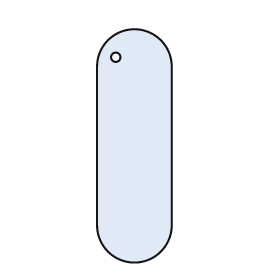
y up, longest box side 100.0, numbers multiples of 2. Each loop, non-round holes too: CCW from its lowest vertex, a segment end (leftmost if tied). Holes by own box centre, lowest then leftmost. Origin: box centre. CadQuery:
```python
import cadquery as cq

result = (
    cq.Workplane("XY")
    .moveTo(-16.0, -34.0)
    .threePointArc((0.0, -50.0), (16.0, -34.0))
    .lineTo(16.0, 34.0)
    .threePointArc((0.0, 50.0), (-16.0, 34.0))
    .close()
    .moveTo(-8.0, 38.0)
    .circle(2.0)
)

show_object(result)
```